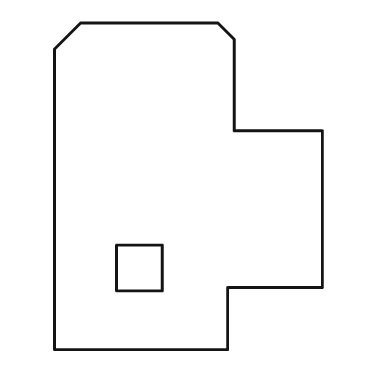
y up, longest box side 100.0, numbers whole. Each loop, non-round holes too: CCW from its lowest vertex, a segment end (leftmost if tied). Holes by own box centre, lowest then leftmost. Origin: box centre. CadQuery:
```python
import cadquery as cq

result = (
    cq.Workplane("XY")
    .moveTo(-41.0, -50.0)
    .lineTo(12.0, -50.0)
    .lineTo(12.0, -31.0)
    .lineTo(41.0, -31.0)
    .lineTo(41.0, 17.0)
    .lineTo(14.0, 17.0)
    .lineTo(14.0, 45.0)
    .lineTo(9.0, 50.0)
    .lineTo(-33.0, 50.0)
    .lineTo(-41.0, 42.0)
    .close()
    .moveTo(-22.0, -32.0)
    .lineTo(-8.0, -32.0)
    .lineTo(-8.0, -18.0)
    .lineTo(-22.0, -18.0)
    .close()
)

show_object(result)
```